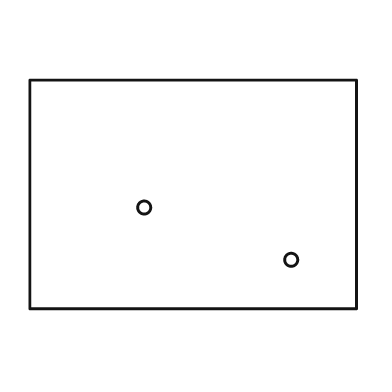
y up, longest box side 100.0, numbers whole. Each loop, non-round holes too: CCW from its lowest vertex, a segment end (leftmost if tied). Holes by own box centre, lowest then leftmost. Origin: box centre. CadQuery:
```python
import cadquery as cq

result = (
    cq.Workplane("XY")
    .moveTo(-50.0, -35.0)
    .lineTo(50.0, -35.0)
    .lineTo(50.0, 35.0)
    .lineTo(-50.0, 35.0)
    .close()
    .moveTo(30.0, -20.0)
    .circle(2.0)
    .moveTo(-15.0, -4.0)
    .circle(2.0)
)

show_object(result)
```